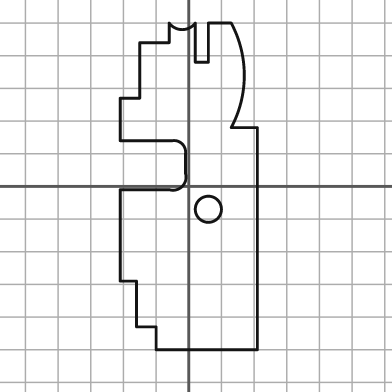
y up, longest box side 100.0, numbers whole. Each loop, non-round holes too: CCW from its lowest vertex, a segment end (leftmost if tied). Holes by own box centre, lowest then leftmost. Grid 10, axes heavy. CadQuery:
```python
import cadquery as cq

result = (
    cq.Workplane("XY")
    .moveTo(-10.0, -50.0)
    .lineTo(21.0, -50.0)
    .lineTo(21.0, 18.0)
    .lineTo(13.0, 18.0)
    .threePointArc((17.0, 34.0), (13.0, 50.0))
    .lineTo(6.0, 50.0)
    .lineTo(6.0, 38.0)
    .lineTo(2.0, 38.0)
    .lineTo(2.0, 50.0)
    .threePointArc((-2.0, 48.0), (-6.0, 50.0))
    .lineTo(-6.0, 44.0)
    .lineTo(-15.0, 44.0)
    .lineTo(-15.0, 27.0)
    .lineTo(-21.0, 27.0)
    .lineTo(-21.0, 14.0)
    .lineTo(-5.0, 14.0)
    .threePointArc((-2.0, 13.0), (-1.0, 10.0))
    .lineTo(-1.0, 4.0)
    .threePointArc((-2.0, 0.0), (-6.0, -1.0))
    .lineTo(-21.0, -1.0)
    .lineTo(-21.0, -29.0)
    .lineTo(-16.0, -29.0)
    .lineTo(-16.0, -43.0)
    .lineTo(-10.0, -43.0)
    .close()
    .moveTo(6.0, -7.0)
    .circle(4.0)
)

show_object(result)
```